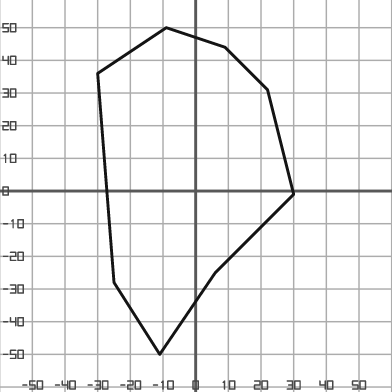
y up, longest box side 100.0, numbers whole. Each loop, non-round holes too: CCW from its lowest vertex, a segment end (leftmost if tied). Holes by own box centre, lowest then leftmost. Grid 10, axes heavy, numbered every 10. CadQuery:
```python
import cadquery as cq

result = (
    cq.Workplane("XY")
    .moveTo(-11.0, -50.0)
    .lineTo(6.0, -25.0)
    .lineTo(30.0, -1.0)
    .lineTo(22.0, 31.0)
    .lineTo(9.0, 44.0)
    .lineTo(-9.0, 50.0)
    .lineTo(-30.0, 36.0)
    .lineTo(-25.0, -28.0)
    .close()
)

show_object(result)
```